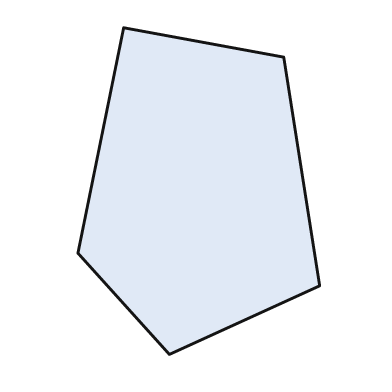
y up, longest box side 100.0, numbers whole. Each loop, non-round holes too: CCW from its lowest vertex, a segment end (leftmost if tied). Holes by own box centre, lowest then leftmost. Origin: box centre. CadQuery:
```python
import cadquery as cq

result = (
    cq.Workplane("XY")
    .moveTo(-9.0, -50.0)
    .lineTo(37.0, -29.0)
    .lineTo(26.0, 41.0)
    .lineTo(-23.0, 50.0)
    .lineTo(-37.0, -19.0)
    .close()
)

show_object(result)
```